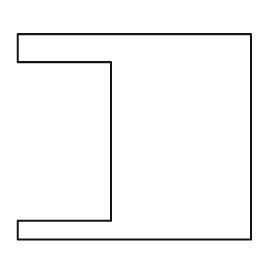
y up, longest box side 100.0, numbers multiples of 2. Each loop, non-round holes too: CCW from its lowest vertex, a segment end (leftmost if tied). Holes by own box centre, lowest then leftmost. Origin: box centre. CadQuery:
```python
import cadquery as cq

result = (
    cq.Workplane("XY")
    .moveTo(-50.0, -44.0)
    .lineTo(50.0, -44.0)
    .lineTo(50.0, 44.0)
    .lineTo(-50.0, 44.0)
    .lineTo(-50.0, 32.0)
    .lineTo(-10.0, 32.0)
    .lineTo(-10.0, -36.0)
    .lineTo(-50.0, -36.0)
    .close()
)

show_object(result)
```